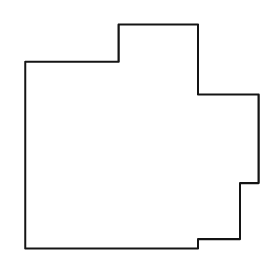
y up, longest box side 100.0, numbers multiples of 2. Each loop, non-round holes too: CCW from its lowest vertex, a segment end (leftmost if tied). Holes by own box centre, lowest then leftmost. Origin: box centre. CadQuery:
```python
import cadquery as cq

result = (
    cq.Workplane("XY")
    .moveTo(-50.0, -48.0)
    .lineTo(24.0, -48.0)
    .lineTo(24.0, -44.0)
    .lineTo(42.0, -44.0)
    .lineTo(42.0, -20.0)
    .lineTo(50.0, -20.0)
    .lineTo(50.0, 18.0)
    .lineTo(24.0, 18.0)
    .lineTo(24.0, 48.0)
    .lineTo(-10.0, 48.0)
    .lineTo(-10.0, 32.0)
    .lineTo(-50.0, 32.0)
    .close()
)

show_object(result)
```